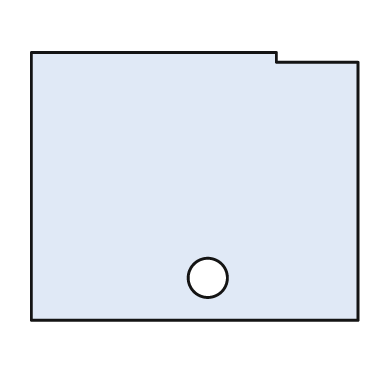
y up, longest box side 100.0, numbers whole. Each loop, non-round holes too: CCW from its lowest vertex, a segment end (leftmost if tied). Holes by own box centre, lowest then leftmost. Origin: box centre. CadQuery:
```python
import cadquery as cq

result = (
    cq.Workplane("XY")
    .moveTo(-50.0, -41.0)
    .lineTo(50.0, -41.0)
    .lineTo(50.0, 38.0)
    .lineTo(25.0, 38.0)
    .lineTo(25.0, 41.0)
    .lineTo(-50.0, 41.0)
    .close()
    .moveTo(4.0, -28.0)
    .circle(6.0)
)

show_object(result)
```